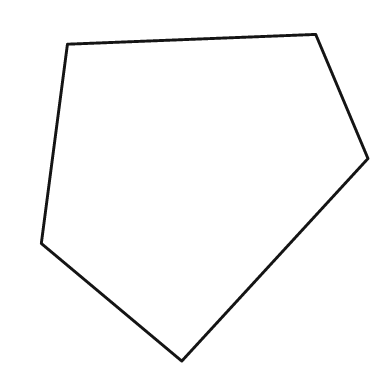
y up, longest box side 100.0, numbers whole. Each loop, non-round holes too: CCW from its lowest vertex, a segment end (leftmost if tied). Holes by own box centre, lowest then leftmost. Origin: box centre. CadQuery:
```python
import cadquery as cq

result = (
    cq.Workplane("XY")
    .moveTo(-7.0, -50.0)
    .lineTo(50.0, 12.0)
    .lineTo(34.0, 50.0)
    .lineTo(-42.0, 47.0)
    .lineTo(-50.0, -14.0)
    .close()
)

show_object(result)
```